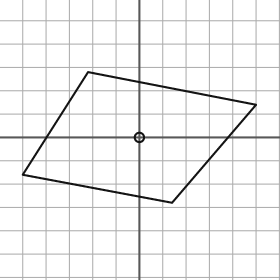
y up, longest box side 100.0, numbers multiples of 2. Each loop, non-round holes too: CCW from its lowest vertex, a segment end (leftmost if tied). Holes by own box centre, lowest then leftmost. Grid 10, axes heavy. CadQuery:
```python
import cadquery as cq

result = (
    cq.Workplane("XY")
    .moveTo(14.0, -28.0)
    .lineTo(50.0, 14.0)
    .lineTo(-22.0, 28.0)
    .lineTo(-50.0, -16.0)
    .close()
    .moveTo(0.0, 0.0)
    .circle(2.0)
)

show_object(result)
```